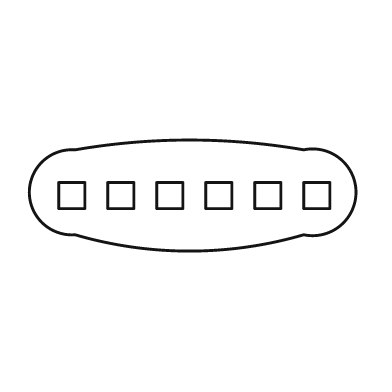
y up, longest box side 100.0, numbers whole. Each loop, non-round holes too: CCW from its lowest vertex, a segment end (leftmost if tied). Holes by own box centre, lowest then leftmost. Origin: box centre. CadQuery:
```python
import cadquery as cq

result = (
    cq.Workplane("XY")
    .moveTo(-36.0, -12.0)
    .threePointArc((-1.0, -17.0), (34.0, -12.0))
    .threePointArc((50.0, 1.0), (34.0, 14.0))
    .threePointArc((-1.0, 17.0), (-36.0, 14.0))
    .threePointArc((-50.0, 1.0), (-36.0, -12.0))
    .close()
    .moveTo(-41.0, -4.0)
    .lineTo(-33.0, -4.0)
    .lineTo(-33.0, 4.0)
    .lineTo(-41.0, 4.0)
    .close()
    .moveTo(-26.0, -4.0)
    .lineTo(-18.0, -4.0)
    .lineTo(-18.0, 4.0)
    .lineTo(-26.0, 4.0)
    .close()
    .moveTo(-11.0, -4.0)
    .lineTo(-3.0, -4.0)
    .lineTo(-3.0, 4.0)
    .lineTo(-11.0, 4.0)
    .close()
    .moveTo(4.0, -4.0)
    .lineTo(12.0, -4.0)
    .lineTo(12.0, 4.0)
    .lineTo(4.0, 4.0)
    .close()
    .moveTo(19.0, -4.0)
    .lineTo(27.0, -4.0)
    .lineTo(27.0, 4.0)
    .lineTo(19.0, 4.0)
    .close()
    .moveTo(34.0, -4.0)
    .lineTo(42.0, -4.0)
    .lineTo(42.0, 4.0)
    .lineTo(34.0, 4.0)
    .close()
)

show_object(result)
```